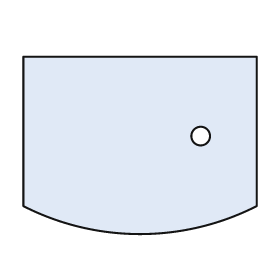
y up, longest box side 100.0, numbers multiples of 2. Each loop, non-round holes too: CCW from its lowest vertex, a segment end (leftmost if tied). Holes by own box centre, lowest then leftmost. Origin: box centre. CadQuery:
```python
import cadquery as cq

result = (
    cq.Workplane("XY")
    .moveTo(-50.0, -26.0)
    .threePointArc((0.0, -38.0), (50.0, -26.0))
    .lineTo(50.0, 38.0)
    .lineTo(-50.0, 38.0)
    .close()
    .moveTo(26.0, 4.0)
    .circle(4.0)
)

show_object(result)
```